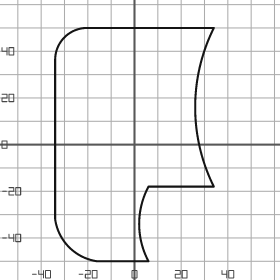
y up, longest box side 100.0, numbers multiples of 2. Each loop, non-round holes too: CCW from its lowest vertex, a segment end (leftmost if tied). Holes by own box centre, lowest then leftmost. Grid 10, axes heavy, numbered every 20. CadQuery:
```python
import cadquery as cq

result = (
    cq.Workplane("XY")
    .moveTo(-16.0, -50.0)
    .lineTo(6.0, -50.0)
    .threePointArc((2.0, -34.0), (6.0, -18.0))
    .lineTo(34.0, -18.0)
    .threePointArc((26.0, 16.0), (34.0, 50.0))
    .lineTo(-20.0, 50.0)
    .threePointArc((-30.0, 46.0), (-34.0, 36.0))
    .lineTo(-34.0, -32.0)
    .threePointArc((-28.0, -44.0), (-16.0, -50.0))
    .close()
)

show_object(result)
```